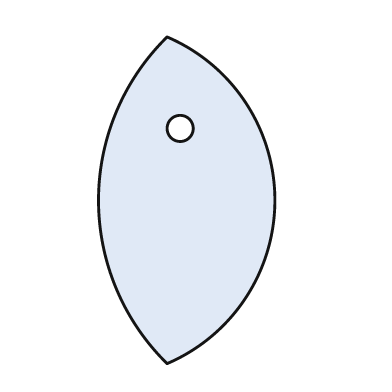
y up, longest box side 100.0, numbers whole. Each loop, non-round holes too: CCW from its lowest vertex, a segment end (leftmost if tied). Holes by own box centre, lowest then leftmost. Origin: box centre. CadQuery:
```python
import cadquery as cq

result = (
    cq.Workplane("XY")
    .moveTo(-6.0, -50.0)
    .threePointArc((27.0, 0.0), (-6.0, 50.0))
    .threePointArc((-27.0, 0.0), (-6.0, -50.0))
    .close()
    .moveTo(-2.0, 22.0)
    .circle(4.0)
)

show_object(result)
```